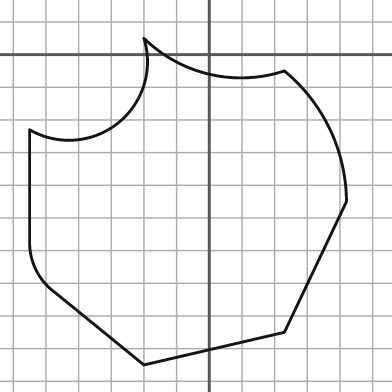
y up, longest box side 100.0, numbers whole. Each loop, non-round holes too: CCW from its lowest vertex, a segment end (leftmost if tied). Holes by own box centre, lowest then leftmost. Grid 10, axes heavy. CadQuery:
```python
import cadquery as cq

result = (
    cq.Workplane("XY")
    .moveTo(-20.0, -95.0)
    .lineTo(23.0, -85.0)
    .lineTo(42.0, -45.0)
    .threePointArc((37.0, -23.0), (23.0, -5.0))
    .threePointArc((0.0, -6.0), (-20.0, 5.0))
    .threePointArc((-28.0, -21.0), (-55.0, -23.0))
    .lineTo(-55.0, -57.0)
    .threePointArc((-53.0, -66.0), (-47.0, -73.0))
    .close()
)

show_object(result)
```